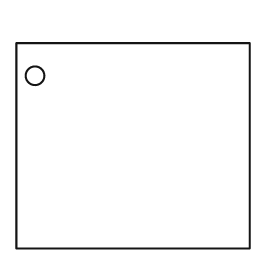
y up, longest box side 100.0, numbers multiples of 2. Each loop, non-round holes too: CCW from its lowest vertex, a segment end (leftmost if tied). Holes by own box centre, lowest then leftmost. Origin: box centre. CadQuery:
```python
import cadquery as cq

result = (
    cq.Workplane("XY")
    .moveTo(-50.0, -44.0)
    .lineTo(50.0, -44.0)
    .lineTo(50.0, 44.0)
    .lineTo(-50.0, 44.0)
    .close()
    .moveTo(-42.0, 30.0)
    .circle(4.0)
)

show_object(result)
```